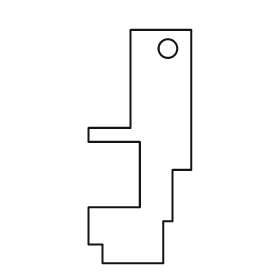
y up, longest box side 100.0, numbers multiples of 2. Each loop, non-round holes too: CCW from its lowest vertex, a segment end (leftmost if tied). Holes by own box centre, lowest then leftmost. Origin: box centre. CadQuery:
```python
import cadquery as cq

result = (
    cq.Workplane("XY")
    .moveTo(-16.0, -50.0)
    .lineTo(10.0, -50.0)
    .lineTo(10.0, -32.0)
    .lineTo(14.0, -32.0)
    .lineTo(14.0, -10.0)
    .lineTo(22.0, -10.0)
    .lineTo(22.0, 50.0)
    .lineTo(-4.0, 50.0)
    .lineTo(-4.0, 8.0)
    .lineTo(-22.0, 8.0)
    .lineTo(-22.0, 2.0)
    .lineTo(0.0, 2.0)
    .lineTo(0.0, -26.0)
    .lineTo(-22.0, -26.0)
    .lineTo(-22.0, -42.0)
    .lineTo(-16.0, -42.0)
    .close()
    .moveTo(12.0, 42.0)
    .circle(4.0)
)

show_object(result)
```